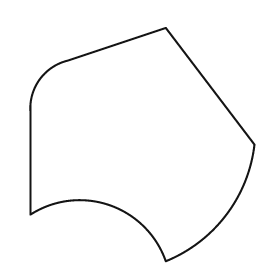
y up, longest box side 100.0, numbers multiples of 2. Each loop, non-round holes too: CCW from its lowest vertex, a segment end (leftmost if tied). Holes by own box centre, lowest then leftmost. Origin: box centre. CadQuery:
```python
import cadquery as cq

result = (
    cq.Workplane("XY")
    .moveTo(10.0, -50.0)
    .threePointArc((36.0, -30.0), (48.0, 0.0))
    .lineTo(10.0, 50.0)
    .lineTo(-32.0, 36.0)
    .threePointArc((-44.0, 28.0), (-48.0, 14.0))
    .lineTo(-48.0, -30.0)
    .threePointArc((-14.0, -26.0), (10.0, -50.0))
    .close()
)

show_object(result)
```